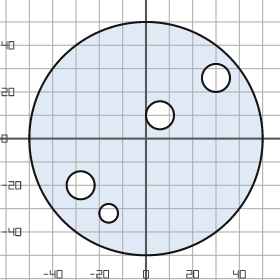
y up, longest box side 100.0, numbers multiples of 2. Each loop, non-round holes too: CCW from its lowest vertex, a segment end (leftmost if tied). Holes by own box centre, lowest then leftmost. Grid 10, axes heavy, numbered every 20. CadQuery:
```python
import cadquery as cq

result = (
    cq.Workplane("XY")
    .moveTo(0.0, 0.0)
    .circle(50.0)
    .moveTo(-16.0, -32.0)
    .circle(4.0)
    .moveTo(-28.0, -20.0)
    .circle(6.0)
    .moveTo(6.0, 10.0)
    .circle(6.0)
    .moveTo(30.0, 26.0)
    .circle(6.0)
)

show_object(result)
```